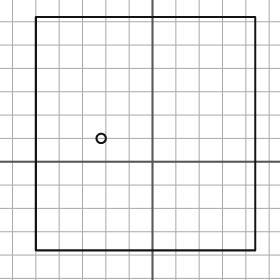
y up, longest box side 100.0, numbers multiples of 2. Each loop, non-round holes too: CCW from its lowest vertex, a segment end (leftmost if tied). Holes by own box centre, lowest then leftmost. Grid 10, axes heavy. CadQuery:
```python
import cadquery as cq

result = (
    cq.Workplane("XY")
    .moveTo(-50.0, -38.0)
    .lineTo(44.0, -38.0)
    .lineTo(44.0, 62.0)
    .lineTo(-50.0, 62.0)
    .close()
    .moveTo(-22.0, 10.0)
    .circle(2.0)
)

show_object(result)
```